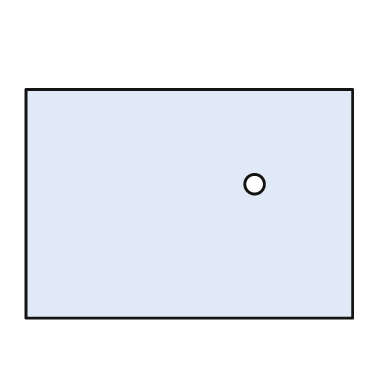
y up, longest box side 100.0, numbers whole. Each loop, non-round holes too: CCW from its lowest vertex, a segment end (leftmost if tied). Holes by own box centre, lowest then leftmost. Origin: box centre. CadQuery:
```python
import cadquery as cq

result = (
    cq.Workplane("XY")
    .moveTo(-50.0, -35.0)
    .lineTo(50.0, -35.0)
    .lineTo(50.0, 35.0)
    .lineTo(-50.0, 35.0)
    .close()
    .moveTo(20.0, 6.0)
    .circle(3.0)
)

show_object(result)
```